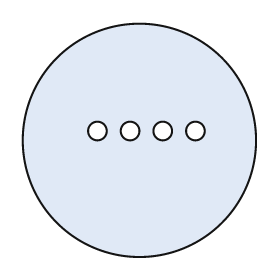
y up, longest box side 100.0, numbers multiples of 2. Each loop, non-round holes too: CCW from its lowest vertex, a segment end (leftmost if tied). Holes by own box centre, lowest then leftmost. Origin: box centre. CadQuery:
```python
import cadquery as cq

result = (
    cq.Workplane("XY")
    .moveTo(0.0, 0.0)
    .circle(50.0)
    .moveTo(-18.0, 4.0)
    .circle(4.0)
    .moveTo(-4.0, 4.0)
    .circle(4.0)
    .moveTo(10.0, 4.0)
    .circle(4.0)
    .moveTo(24.0, 4.0)
    .circle(4.0)
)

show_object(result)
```